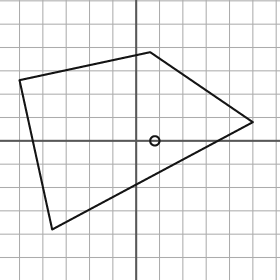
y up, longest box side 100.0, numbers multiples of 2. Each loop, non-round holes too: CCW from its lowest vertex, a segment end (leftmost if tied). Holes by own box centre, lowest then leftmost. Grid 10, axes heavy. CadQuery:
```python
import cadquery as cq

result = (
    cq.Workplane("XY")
    .moveTo(-36.0, -38.0)
    .lineTo(50.0, 8.0)
    .lineTo(6.0, 38.0)
    .lineTo(-50.0, 26.0)
    .close()
    .moveTo(8.0, 0.0)
    .circle(2.0)
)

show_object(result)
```